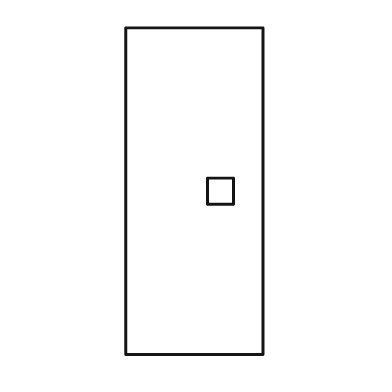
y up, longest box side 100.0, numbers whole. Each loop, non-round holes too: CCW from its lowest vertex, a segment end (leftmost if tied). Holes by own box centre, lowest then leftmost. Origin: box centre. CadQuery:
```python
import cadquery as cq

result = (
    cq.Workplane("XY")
    .moveTo(-21.0, -50.0)
    .lineTo(21.0, -50.0)
    .lineTo(21.0, 50.0)
    .lineTo(-21.0, 50.0)
    .close()
    .moveTo(4.0, -4.0)
    .lineTo(12.0, -4.0)
    .lineTo(12.0, 4.0)
    .lineTo(4.0, 4.0)
    .close()
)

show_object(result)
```